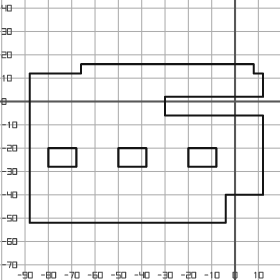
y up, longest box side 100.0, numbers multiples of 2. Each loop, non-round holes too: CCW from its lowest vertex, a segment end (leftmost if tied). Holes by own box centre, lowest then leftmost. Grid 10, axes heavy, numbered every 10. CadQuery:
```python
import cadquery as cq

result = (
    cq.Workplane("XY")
    .moveTo(-88.0, -52.0)
    .lineTo(-4.0, -52.0)
    .lineTo(-4.0, -40.0)
    .lineTo(12.0, -40.0)
    .lineTo(12.0, -6.0)
    .lineTo(-30.0, -6.0)
    .lineTo(-30.0, 2.0)
    .lineTo(12.0, 2.0)
    .lineTo(12.0, 12.0)
    .lineTo(8.0, 12.0)
    .lineTo(8.0, 16.0)
    .lineTo(-66.0, 16.0)
    .lineTo(-66.0, 12.0)
    .lineTo(-88.0, 12.0)
    .close()
    .moveTo(-80.0, -28.0)
    .lineTo(-68.0, -28.0)
    .lineTo(-68.0, -20.0)
    .lineTo(-80.0, -20.0)
    .close()
    .moveTo(-50.0, -28.0)
    .lineTo(-38.0, -28.0)
    .lineTo(-38.0, -20.0)
    .lineTo(-50.0, -20.0)
    .close()
    .moveTo(-20.0, -28.0)
    .lineTo(-8.0, -28.0)
    .lineTo(-8.0, -20.0)
    .lineTo(-20.0, -20.0)
    .close()
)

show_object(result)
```